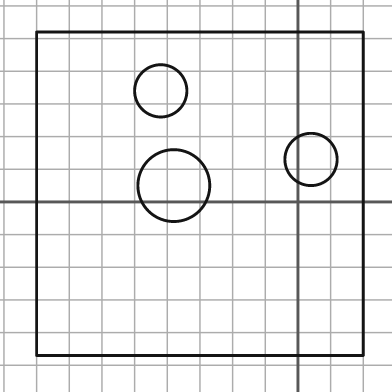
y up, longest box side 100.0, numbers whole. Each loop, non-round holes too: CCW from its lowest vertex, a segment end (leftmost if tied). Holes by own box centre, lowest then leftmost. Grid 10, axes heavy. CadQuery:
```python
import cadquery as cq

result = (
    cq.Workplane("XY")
    .moveTo(-80.0, -47.0)
    .lineTo(20.0, -47.0)
    .lineTo(20.0, 52.0)
    .lineTo(-80.0, 52.0)
    .close()
    .moveTo(-38.0, 5.0)
    .circle(11.0)
    .moveTo(4.0, 13.0)
    .circle(8.0)
    .moveTo(-42.0, 34.0)
    .circle(8.0)
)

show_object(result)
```